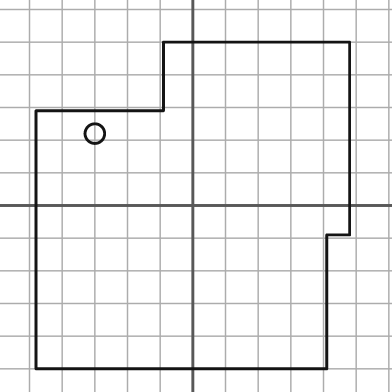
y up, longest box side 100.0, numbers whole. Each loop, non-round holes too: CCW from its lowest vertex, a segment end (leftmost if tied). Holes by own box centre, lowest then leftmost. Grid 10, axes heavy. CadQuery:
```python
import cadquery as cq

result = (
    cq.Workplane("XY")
    .moveTo(-48.0, -50.0)
    .lineTo(41.0, -50.0)
    .lineTo(41.0, -9.0)
    .lineTo(48.0, -9.0)
    .lineTo(48.0, 50.0)
    .lineTo(-9.0, 50.0)
    .lineTo(-9.0, 29.0)
    .lineTo(-48.0, 29.0)
    .close()
    .moveTo(-30.0, 22.0)
    .circle(3.0)
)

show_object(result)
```